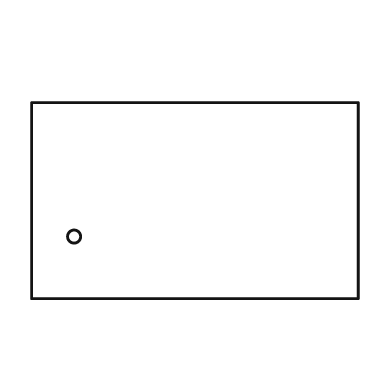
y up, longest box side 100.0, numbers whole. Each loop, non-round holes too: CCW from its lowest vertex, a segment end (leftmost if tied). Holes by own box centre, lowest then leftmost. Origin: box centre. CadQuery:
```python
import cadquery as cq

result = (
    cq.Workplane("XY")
    .moveTo(-50.0, -30.0)
    .lineTo(50.0, -30.0)
    .lineTo(50.0, 30.0)
    .lineTo(-50.0, 30.0)
    .close()
    .moveTo(-37.0, -11.0)
    .circle(2.0)
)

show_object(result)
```